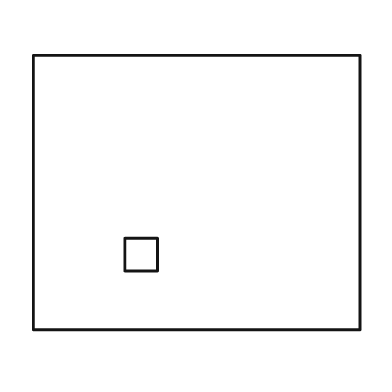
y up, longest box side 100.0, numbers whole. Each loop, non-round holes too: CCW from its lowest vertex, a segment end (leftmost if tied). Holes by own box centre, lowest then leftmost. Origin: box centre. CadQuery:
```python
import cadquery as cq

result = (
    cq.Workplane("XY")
    .moveTo(-50.0, -42.0)
    .lineTo(50.0, -42.0)
    .lineTo(50.0, 42.0)
    .lineTo(-50.0, 42.0)
    .close()
    .moveTo(-22.0, -24.0)
    .lineTo(-12.0, -24.0)
    .lineTo(-12.0, -14.0)
    .lineTo(-22.0, -14.0)
    .close()
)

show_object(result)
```